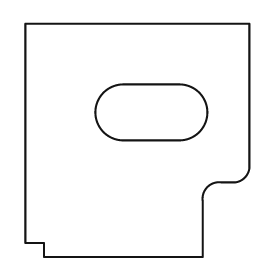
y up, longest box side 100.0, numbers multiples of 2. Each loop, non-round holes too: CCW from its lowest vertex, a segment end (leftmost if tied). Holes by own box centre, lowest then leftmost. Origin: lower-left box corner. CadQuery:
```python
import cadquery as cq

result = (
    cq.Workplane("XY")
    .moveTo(8.0, 0.0)
    .lineTo(76.0, 0.0)
    .lineTo(76.0, 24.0)
    .threePointArc((78.0, 30.0), (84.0, 32.0))
    .lineTo(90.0, 32.0)
    .threePointArc((94.0, 34.0), (96.0, 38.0))
    .lineTo(96.0, 100.0)
    .lineTo(0.0, 100.0)
    .lineTo(0.0, 6.0)
    .lineTo(8.0, 6.0)
    .close()
    .moveTo(42.0, 50.0)
    .lineTo(66.0, 50.0)
    .threePointArc((78.0, 62.0), (66.0, 74.0))
    .lineTo(42.0, 74.0)
    .threePointArc((30.0, 62.0), (42.0, 50.0))
    .close()
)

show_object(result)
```